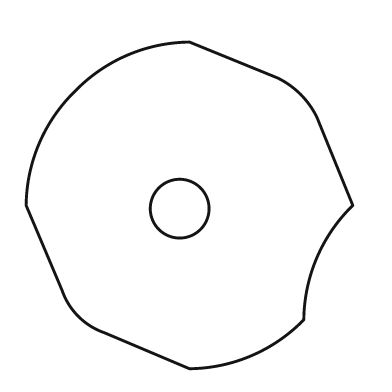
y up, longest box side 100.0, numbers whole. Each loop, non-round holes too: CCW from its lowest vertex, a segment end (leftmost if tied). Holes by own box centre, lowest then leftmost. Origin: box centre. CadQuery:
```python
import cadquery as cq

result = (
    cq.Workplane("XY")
    .moveTo(0.0, -50.0)
    .threePointArc((19.0, -46.0), (35.0, -35.0))
    .threePointArc((39.0, -16.0), (50.0, 0.0))
    .lineTo(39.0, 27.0)
    .threePointArc((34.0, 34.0), (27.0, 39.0))
    .lineTo(0.0, 50.0)
    .threePointArc((-19.0, 46.0), (-35.0, 35.0))
    .threePointArc((-46.0, 19.0), (-50.0, 0.0))
    .lineTo(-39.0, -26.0)
    .threePointArc((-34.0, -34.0), (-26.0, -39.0))
    .close()
    .moveTo(-3.0, -1.0)
    .circle(9.0)
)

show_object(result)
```